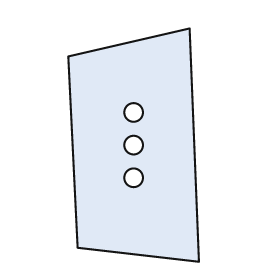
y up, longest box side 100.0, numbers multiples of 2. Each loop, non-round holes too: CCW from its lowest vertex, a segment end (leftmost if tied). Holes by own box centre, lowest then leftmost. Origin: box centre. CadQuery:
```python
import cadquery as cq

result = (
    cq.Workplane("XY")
    .moveTo(28.0, -50.0)
    .lineTo(24.0, 50.0)
    .lineTo(-28.0, 38.0)
    .lineTo(-24.0, -44.0)
    .close()
    .moveTo(0.0, -14.0)
    .circle(4.0)
    .moveTo(0.0, 0.0)
    .circle(4.0)
    .moveTo(0.0, 14.0)
    .circle(4.0)
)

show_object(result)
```